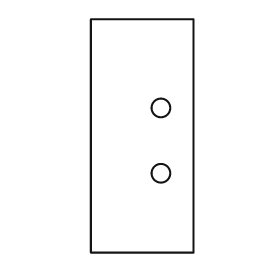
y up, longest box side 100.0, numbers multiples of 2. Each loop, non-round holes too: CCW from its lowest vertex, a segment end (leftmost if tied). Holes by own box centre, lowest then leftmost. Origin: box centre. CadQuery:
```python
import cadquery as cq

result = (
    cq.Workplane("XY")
    .moveTo(-22.0, -50.0)
    .lineTo(22.0, -50.0)
    .lineTo(22.0, 50.0)
    .lineTo(-22.0, 50.0)
    .close()
    .moveTo(8.0, -16.0)
    .circle(4.0)
    .moveTo(8.0, 12.0)
    .circle(4.0)
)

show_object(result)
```